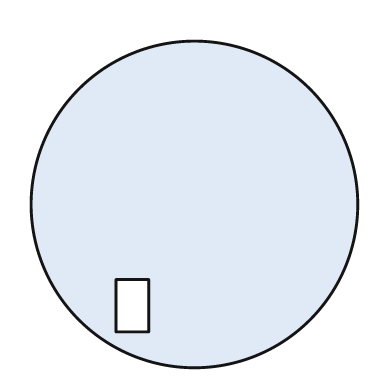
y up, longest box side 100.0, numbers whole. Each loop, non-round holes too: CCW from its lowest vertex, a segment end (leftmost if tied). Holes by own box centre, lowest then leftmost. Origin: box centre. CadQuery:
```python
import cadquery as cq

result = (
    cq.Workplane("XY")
    .moveTo(0.0, 0.0)
    .circle(50.0)
    .moveTo(-24.0, -39.0)
    .lineTo(-14.0, -39.0)
    .lineTo(-14.0, -23.0)
    .lineTo(-24.0, -23.0)
    .close()
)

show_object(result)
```